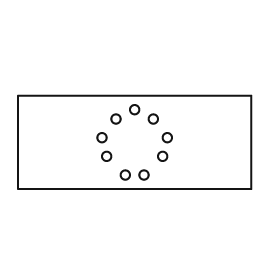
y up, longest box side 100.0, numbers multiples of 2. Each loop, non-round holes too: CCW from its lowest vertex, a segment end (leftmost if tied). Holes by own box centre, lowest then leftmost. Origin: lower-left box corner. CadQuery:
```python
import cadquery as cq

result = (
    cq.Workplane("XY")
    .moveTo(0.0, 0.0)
    .lineTo(100.0, 0.0)
    .lineTo(100.0, 40.0)
    .lineTo(0.0, 40.0)
    .close()
    .moveTo(46.0, 6.0)
    .circle(2.0)
    .moveTo(54.0, 6.0)
    .circle(2.0)
    .moveTo(38.0, 14.0)
    .circle(2.0)
    .moveTo(62.0, 14.0)
    .circle(2.0)
    .moveTo(36.0, 22.0)
    .circle(2.0)
    .moveTo(64.0, 22.0)
    .circle(2.0)
    .moveTo(42.0, 30.0)
    .circle(2.0)
    .moveTo(58.0, 30.0)
    .circle(2.0)
    .moveTo(50.0, 34.0)
    .circle(2.0)
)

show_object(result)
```